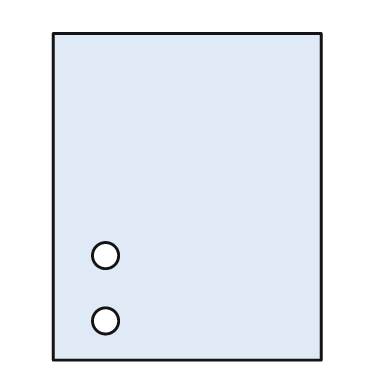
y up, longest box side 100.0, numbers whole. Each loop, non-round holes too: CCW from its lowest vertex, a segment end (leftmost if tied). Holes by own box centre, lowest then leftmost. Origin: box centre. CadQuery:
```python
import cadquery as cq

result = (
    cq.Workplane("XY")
    .moveTo(-41.0, -50.0)
    .lineTo(41.0, -50.0)
    .lineTo(41.0, 50.0)
    .lineTo(-41.0, 50.0)
    .close()
    .moveTo(-25.0, -38.0)
    .circle(4.0)
    .moveTo(-25.0, -18.0)
    .circle(4.0)
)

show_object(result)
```